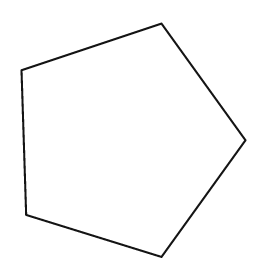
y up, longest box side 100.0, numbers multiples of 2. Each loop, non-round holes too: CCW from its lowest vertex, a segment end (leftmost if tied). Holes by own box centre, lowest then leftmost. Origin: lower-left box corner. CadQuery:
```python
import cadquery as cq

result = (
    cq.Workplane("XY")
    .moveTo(60.0, 0.0)
    .lineTo(96.0, 50.0)
    .lineTo(60.0, 100.0)
    .lineTo(0.0, 80.0)
    .lineTo(2.0, 18.0)
    .close()
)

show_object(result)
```